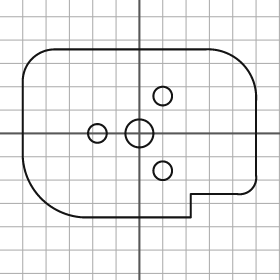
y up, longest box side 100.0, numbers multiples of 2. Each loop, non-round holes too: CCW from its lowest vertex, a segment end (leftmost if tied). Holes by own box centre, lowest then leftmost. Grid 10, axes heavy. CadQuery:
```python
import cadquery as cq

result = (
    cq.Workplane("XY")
    .moveTo(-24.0, -36.0)
    .lineTo(22.0, -36.0)
    .lineTo(22.0, -26.0)
    .lineTo(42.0, -26.0)
    .threePointArc((48.0, -24.0), (50.0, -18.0))
    .lineTo(50.0, 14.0)
    .threePointArc((44.0, 30.0), (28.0, 36.0))
    .lineTo(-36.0, 36.0)
    .threePointArc((-46.0, 32.0), (-50.0, 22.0))
    .lineTo(-50.0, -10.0)
    .threePointArc((-42.0, -28.0), (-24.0, -36.0))
    .close()
    .moveTo(10.0, -16.0)
    .circle(4.0)
    .moveTo(-18.0, 0.0)
    .circle(4.0)
    .moveTo(0.0, 0.0)
    .circle(6.0)
    .moveTo(10.0, 16.0)
    .circle(4.0)
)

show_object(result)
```